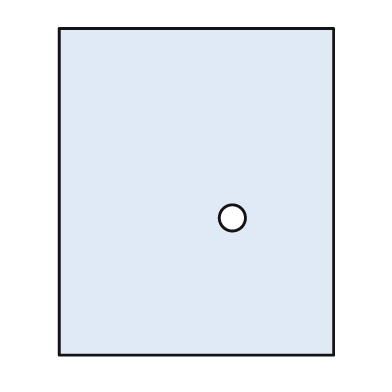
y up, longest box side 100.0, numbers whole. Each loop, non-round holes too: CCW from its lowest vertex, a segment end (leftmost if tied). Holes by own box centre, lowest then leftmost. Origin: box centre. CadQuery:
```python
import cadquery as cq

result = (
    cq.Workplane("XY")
    .moveTo(-42.0, -50.0)
    .lineTo(42.0, -50.0)
    .lineTo(42.0, 50.0)
    .lineTo(-42.0, 50.0)
    .close()
    .moveTo(11.0, -8.0)
    .circle(4.0)
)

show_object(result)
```